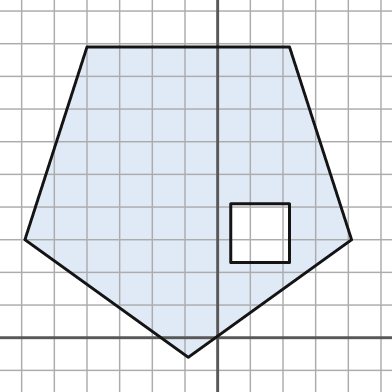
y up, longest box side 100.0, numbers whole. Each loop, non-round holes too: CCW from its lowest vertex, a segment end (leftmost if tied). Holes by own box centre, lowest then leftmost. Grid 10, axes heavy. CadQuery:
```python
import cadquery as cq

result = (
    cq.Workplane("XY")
    .moveTo(-9.0, -6.0)
    .lineTo(41.0, 30.0)
    .lineTo(22.0, 89.0)
    .lineTo(-40.0, 89.0)
    .lineTo(-59.0, 30.0)
    .close()
    .moveTo(4.0, 23.0)
    .lineTo(22.0, 23.0)
    .lineTo(22.0, 41.0)
    .lineTo(4.0, 41.0)
    .close()
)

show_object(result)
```